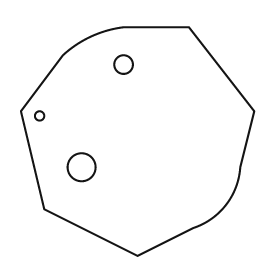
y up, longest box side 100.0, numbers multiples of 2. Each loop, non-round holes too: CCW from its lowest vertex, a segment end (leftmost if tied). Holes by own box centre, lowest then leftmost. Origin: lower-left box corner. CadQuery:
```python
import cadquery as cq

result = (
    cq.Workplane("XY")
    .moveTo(50.0, 0.0)
    .lineTo(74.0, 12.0)
    .threePointArc((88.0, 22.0), (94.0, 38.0))
    .lineTo(100.0, 62.0)
    .lineTo(72.0, 98.0)
    .lineTo(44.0, 98.0)
    .threePointArc((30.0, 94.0), (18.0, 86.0))
    .lineTo(0.0, 62.0)
    .lineTo(10.0, 20.0)
    .close()
    .moveTo(26.0, 38.0)
    .circle(6.0)
    .moveTo(8.0, 60.0)
    .circle(2.0)
    .moveTo(44.0, 82.0)
    .circle(4.0)
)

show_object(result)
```